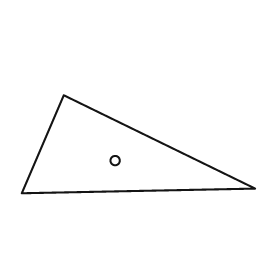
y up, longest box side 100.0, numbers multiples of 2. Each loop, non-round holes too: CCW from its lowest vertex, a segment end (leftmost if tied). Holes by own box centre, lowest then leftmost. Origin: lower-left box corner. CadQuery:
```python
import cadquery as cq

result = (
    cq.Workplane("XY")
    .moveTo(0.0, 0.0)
    .lineTo(100.0, 2.0)
    .lineTo(18.0, 42.0)
    .close()
    .moveTo(40.0, 14.0)
    .circle(2.0)
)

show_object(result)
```